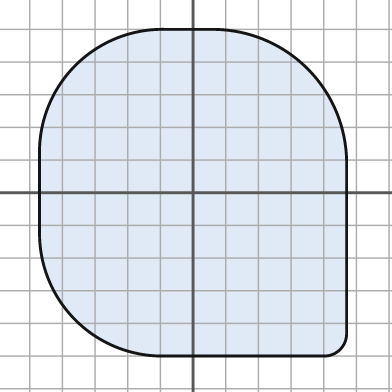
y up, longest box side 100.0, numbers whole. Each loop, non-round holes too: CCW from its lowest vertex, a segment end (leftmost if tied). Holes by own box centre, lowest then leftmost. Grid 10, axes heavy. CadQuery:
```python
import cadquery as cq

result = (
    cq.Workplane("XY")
    .moveTo(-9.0, -50.0)
    .lineTo(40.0, -50.0)
    .threePointArc((45.0, -48.0), (47.0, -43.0))
    .lineTo(47.0, 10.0)
    .threePointArc((35.0, 38.0), (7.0, 50.0))
    .lineTo(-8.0, 50.0)
    .threePointArc((-36.0, 39.0), (-47.0, 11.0))
    .lineTo(-47.0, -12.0)
    .threePointArc((-36.0, -39.0), (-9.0, -50.0))
    .close()
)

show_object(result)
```